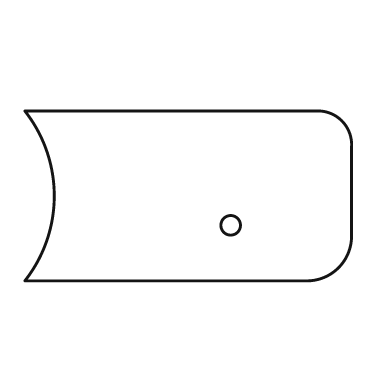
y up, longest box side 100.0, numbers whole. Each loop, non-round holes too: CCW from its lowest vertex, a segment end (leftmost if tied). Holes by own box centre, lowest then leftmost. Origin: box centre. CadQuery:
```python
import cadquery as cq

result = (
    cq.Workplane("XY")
    .moveTo(-50.0, -26.0)
    .lineTo(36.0, -26.0)
    .threePointArc((46.0, -22.0), (50.0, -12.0))
    .lineTo(50.0, 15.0)
    .threePointArc((47.0, 23.0), (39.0, 26.0))
    .lineTo(-50.0, 26.0)
    .threePointArc((-41.0, 0.0), (-50.0, -26.0))
    .close()
    .moveTo(13.0, -9.0)
    .circle(3.0)
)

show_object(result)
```